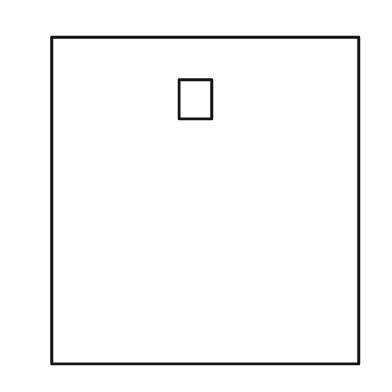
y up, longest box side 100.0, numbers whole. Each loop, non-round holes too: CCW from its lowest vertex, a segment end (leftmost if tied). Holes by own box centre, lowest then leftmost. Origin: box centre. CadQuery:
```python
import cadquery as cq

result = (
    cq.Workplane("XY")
    .moveTo(-47.0, -50.0)
    .lineTo(47.0, -50.0)
    .lineTo(47.0, 50.0)
    .lineTo(-47.0, 50.0)
    .close()
    .moveTo(-8.0, 25.0)
    .lineTo(2.0, 25.0)
    .lineTo(2.0, 37.0)
    .lineTo(-8.0, 37.0)
    .close()
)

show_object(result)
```